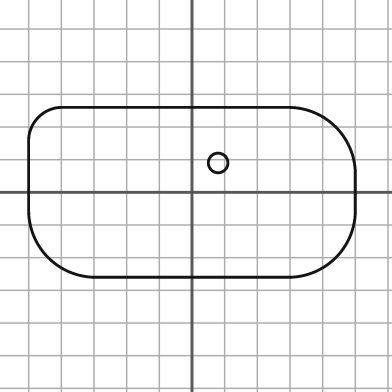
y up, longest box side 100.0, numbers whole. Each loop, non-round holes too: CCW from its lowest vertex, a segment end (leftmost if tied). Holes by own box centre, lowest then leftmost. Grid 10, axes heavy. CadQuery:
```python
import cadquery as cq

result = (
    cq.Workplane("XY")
    .moveTo(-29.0, -26.0)
    .lineTo(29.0, -26.0)
    .threePointArc((44.0, -20.0), (50.0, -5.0))
    .lineTo(50.0, 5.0)
    .threePointArc((44.0, 20.0), (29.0, 26.0))
    .lineTo(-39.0, 26.0)
    .threePointArc((-47.0, 23.0), (-50.0, 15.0))
    .lineTo(-50.0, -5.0)
    .threePointArc((-44.0, -20.0), (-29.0, -26.0))
    .close()
    .moveTo(8.0, 9.0)
    .circle(3.0)
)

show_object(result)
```